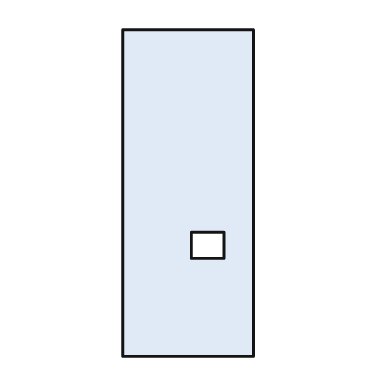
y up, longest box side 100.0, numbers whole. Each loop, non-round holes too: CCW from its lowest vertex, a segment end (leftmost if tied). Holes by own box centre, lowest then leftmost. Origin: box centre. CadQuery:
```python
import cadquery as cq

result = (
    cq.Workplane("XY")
    .moveTo(-20.0, -50.0)
    .lineTo(20.0, -50.0)
    .lineTo(20.0, 50.0)
    .lineTo(-20.0, 50.0)
    .close()
    .moveTo(1.0, -20.0)
    .lineTo(11.0, -20.0)
    .lineTo(11.0, -12.0)
    .lineTo(1.0, -12.0)
    .close()
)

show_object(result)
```